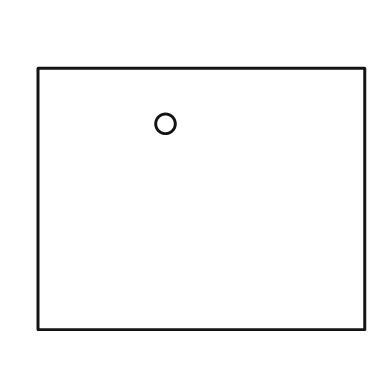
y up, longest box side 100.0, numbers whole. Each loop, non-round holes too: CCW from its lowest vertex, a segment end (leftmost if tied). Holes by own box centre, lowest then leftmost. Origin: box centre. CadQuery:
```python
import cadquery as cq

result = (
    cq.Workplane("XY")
    .moveTo(-50.0, -40.0)
    .lineTo(50.0, -40.0)
    .lineTo(50.0, 40.0)
    .lineTo(-50.0, 40.0)
    .close()
    .moveTo(-11.0, 23.0)
    .circle(3.0)
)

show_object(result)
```